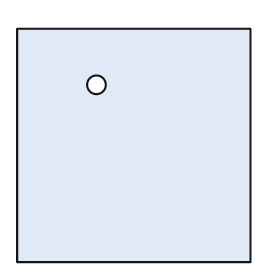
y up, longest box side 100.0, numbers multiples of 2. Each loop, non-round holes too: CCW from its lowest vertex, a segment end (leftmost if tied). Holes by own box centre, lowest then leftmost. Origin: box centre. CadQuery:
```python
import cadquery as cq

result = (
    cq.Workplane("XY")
    .moveTo(-50.0, -50.0)
    .lineTo(50.0, -50.0)
    .lineTo(50.0, 50.0)
    .lineTo(-50.0, 50.0)
    .close()
    .moveTo(-16.0, 26.0)
    .circle(4.0)
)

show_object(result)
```